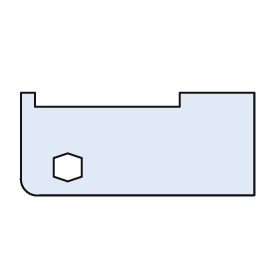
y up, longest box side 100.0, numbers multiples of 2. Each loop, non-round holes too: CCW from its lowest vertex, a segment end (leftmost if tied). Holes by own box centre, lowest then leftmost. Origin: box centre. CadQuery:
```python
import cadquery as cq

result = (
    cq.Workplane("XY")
    .moveTo(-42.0, -22.0)
    .lineTo(50.0, -22.0)
    .lineTo(50.0, 22.0)
    .lineTo(18.0, 22.0)
    .lineTo(18.0, 16.0)
    .lineTo(-44.0, 16.0)
    .lineTo(-44.0, 22.0)
    .lineTo(-50.0, 22.0)
    .lineTo(-50.0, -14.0)
    .threePointArc((-48.0, -20.0), (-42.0, -22.0))
    .close()
    .moveTo(-30.0, -16.0)
    .lineTo(-24.0, -14.0)
    .lineTo(-24.0, -6.0)
    .lineTo(-30.0, -4.0)
    .lineTo(-36.0, -6.0)
    .lineTo(-36.0, -14.0)
    .close()
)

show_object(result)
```